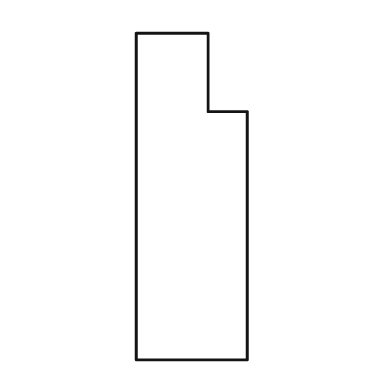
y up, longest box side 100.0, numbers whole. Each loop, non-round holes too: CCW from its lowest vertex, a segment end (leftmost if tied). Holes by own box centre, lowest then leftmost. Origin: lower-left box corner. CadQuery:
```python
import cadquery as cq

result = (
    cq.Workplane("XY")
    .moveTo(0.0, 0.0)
    .lineTo(34.0, 0.0)
    .lineTo(34.0, 76.0)
    .lineTo(22.0, 76.0)
    .lineTo(22.0, 100.0)
    .lineTo(0.0, 100.0)
    .close()
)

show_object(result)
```